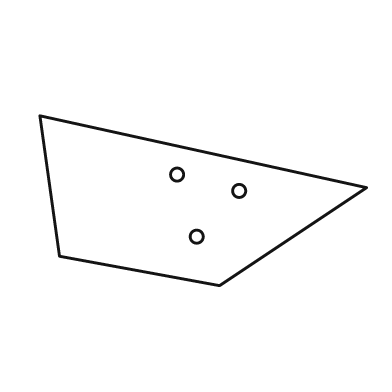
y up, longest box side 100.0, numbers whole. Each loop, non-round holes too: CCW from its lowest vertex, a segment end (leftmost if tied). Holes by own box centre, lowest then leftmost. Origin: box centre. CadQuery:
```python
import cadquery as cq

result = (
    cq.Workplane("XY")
    .moveTo(5.0, -26.0)
    .lineTo(50.0, 4.0)
    .lineTo(-50.0, 26.0)
    .lineTo(-44.0, -17.0)
    .close()
    .moveTo(-2.0, -11.0)
    .circle(2.0)
    .moveTo(11.0, 3.0)
    .circle(2.0)
    .moveTo(-8.0, 8.0)
    .circle(2.0)
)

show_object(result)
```